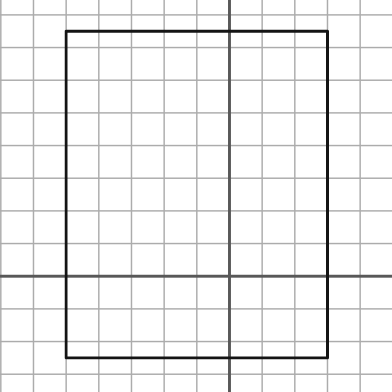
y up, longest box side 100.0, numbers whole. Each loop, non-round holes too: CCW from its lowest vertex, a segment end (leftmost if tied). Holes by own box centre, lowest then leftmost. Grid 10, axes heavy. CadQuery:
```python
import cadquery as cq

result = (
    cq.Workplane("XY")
    .moveTo(-50.0, -25.0)
    .lineTo(30.0, -25.0)
    .lineTo(30.0, 75.0)
    .lineTo(-50.0, 75.0)
    .close()
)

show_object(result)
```